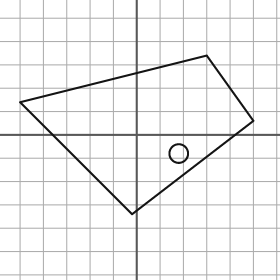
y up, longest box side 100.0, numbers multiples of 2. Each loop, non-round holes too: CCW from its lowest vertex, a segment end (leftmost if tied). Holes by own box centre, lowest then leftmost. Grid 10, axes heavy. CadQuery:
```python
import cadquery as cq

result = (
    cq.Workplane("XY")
    .moveTo(-2.0, -34.0)
    .lineTo(50.0, 6.0)
    .lineTo(30.0, 34.0)
    .lineTo(-50.0, 14.0)
    .close()
    .moveTo(18.0, -8.0)
    .circle(4.0)
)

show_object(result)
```